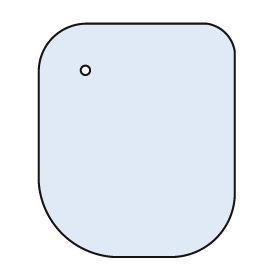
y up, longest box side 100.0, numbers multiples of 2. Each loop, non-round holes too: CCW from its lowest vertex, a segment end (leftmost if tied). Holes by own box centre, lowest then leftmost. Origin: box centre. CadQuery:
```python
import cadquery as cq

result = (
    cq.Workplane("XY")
    .moveTo(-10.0, -50.0)
    .lineTo(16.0, -50.0)
    .threePointArc((34.0, -42.0), (42.0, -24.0))
    .lineTo(42.0, 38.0)
    .threePointArc((38.0, 46.0), (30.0, 50.0))
    .lineTo(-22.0, 50.0)
    .threePointArc((-36.0, 44.0), (-42.0, 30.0))
    .lineTo(-42.0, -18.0)
    .threePointArc((-32.0, -40.0), (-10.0, -50.0))
    .close()
    .moveTo(-22.0, 30.0)
    .circle(2.0)
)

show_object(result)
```